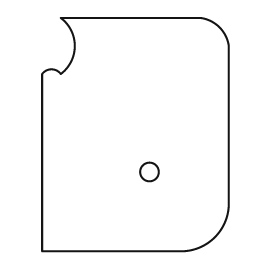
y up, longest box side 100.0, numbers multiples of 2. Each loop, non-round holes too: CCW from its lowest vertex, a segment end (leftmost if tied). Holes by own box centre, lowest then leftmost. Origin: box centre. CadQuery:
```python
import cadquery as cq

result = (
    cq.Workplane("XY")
    .moveTo(-40.0, -50.0)
    .lineTo(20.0, -50.0)
    .threePointArc((34.0, -44.0), (40.0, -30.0))
    .lineTo(40.0, 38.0)
    .threePointArc((36.0, 46.0), (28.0, 50.0))
    .lineTo(-32.0, 50.0)
    .threePointArc((-26.0, 38.0), (-32.0, 26.0))
    .threePointArc((-36.0, 28.0), (-40.0, 26.0))
    .close()
    .moveTo(6.0, -16.0)
    .circle(4.0)
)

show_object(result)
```